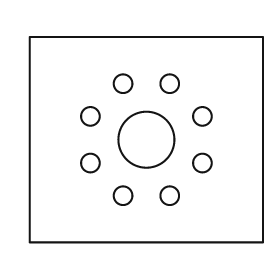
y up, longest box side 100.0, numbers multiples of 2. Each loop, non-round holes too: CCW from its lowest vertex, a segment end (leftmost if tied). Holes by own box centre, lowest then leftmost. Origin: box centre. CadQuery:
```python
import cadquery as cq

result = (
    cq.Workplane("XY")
    .moveTo(-50.0, -44.0)
    .lineTo(50.0, -44.0)
    .lineTo(50.0, 44.0)
    .lineTo(-50.0, 44.0)
    .close()
    .moveTo(-10.0, -24.0)
    .circle(4.0)
    .moveTo(10.0, -24.0)
    .circle(4.0)
    .moveTo(-24.0, -10.0)
    .circle(4.0)
    .moveTo(24.0, -10.0)
    .circle(4.0)
    .moveTo(0.0, 0.0)
    .circle(12.0)
    .moveTo(-24.0, 10.0)
    .circle(4.0)
    .moveTo(24.0, 10.0)
    .circle(4.0)
    .moveTo(-10.0, 24.0)
    .circle(4.0)
    .moveTo(10.0, 24.0)
    .circle(4.0)
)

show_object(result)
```